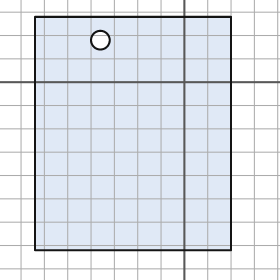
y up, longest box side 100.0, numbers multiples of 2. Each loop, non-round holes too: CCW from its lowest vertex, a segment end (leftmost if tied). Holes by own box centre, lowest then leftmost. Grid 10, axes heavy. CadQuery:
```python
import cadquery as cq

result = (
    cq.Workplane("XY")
    .moveTo(-64.0, -72.0)
    .lineTo(20.0, -72.0)
    .lineTo(20.0, 28.0)
    .lineTo(-64.0, 28.0)
    .close()
    .moveTo(-36.0, 18.0)
    .circle(4.0)
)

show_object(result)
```